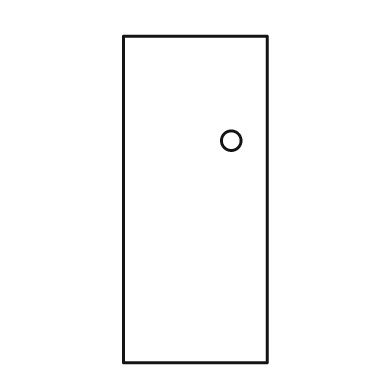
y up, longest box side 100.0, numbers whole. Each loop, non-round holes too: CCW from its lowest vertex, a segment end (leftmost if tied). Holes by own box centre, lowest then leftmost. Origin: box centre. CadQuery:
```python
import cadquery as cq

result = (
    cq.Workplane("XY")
    .moveTo(-22.0, -50.0)
    .lineTo(22.0, -50.0)
    .lineTo(22.0, 50.0)
    .lineTo(-22.0, 50.0)
    .close()
    .moveTo(11.0, 18.0)
    .circle(3.0)
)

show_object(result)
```